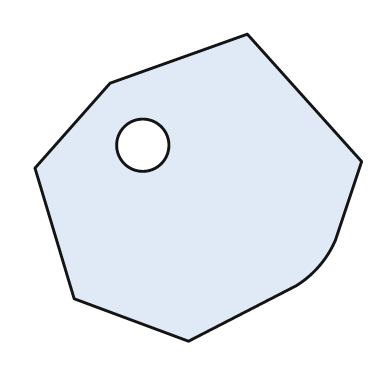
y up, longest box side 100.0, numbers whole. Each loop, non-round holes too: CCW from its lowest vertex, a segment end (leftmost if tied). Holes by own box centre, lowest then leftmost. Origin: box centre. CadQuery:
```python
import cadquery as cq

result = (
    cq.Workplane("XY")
    .moveTo(-3.0, -47.0)
    .lineTo(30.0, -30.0)
    .threePointArc((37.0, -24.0), (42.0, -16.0))
    .lineTo(50.0, 8.0)
    .lineTo(15.0, 47.0)
    .lineTo(-27.0, 32.0)
    .lineTo(-50.0, 6.0)
    .lineTo(-38.0, -34.0)
    .close()
    .moveTo(-17.0, 13.0)
    .circle(8.0)
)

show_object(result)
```